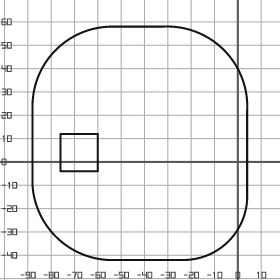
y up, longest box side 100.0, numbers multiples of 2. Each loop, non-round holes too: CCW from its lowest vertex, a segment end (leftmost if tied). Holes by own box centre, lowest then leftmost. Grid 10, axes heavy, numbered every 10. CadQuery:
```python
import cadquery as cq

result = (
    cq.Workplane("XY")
    .moveTo(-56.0, -42.0)
    .lineTo(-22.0, -42.0)
    .threePointArc((-4.0, -34.0), (4.0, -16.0))
    .lineTo(4.0, 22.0)
    .threePointArc((-6.0, 48.0), (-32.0, 58.0))
    .lineTo(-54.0, 58.0)
    .threePointArc((-78.0, 48.0), (-88.0, 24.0))
    .lineTo(-88.0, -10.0)
    .threePointArc((-78.0, -32.0), (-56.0, -42.0))
    .close()
    .moveTo(-76.0, -4.0)
    .lineTo(-60.0, -4.0)
    .lineTo(-60.0, 12.0)
    .lineTo(-76.0, 12.0)
    .close()
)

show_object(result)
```